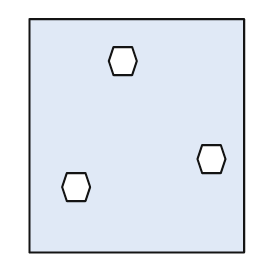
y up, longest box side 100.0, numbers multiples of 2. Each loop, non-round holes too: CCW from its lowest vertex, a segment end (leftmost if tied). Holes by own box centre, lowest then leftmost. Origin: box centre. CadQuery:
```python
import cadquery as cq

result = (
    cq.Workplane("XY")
    .moveTo(-46.0, -50.0)
    .lineTo(46.0, -50.0)
    .lineTo(46.0, 50.0)
    .lineTo(-46.0, 50.0)
    .close()
    .moveTo(-30.0, -28.0)
    .lineTo(-22.0, -28.0)
    .lineTo(-20.0, -22.0)
    .lineTo(-22.0, -16.0)
    .lineTo(-30.0, -16.0)
    .lineTo(-32.0, -22.0)
    .close()
    .moveTo(28.0, -16.0)
    .lineTo(36.0, -16.0)
    .lineTo(38.0, -10.0)
    .lineTo(36.0, -4.0)
    .lineTo(28.0, -4.0)
    .lineTo(26.0, -10.0)
    .close()
    .moveTo(-10.0, 26.0)
    .lineTo(-2.0, 26.0)
    .lineTo(0.0, 32.0)
    .lineTo(-2.0, 38.0)
    .lineTo(-10.0, 38.0)
    .lineTo(-12.0, 32.0)
    .close()
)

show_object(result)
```